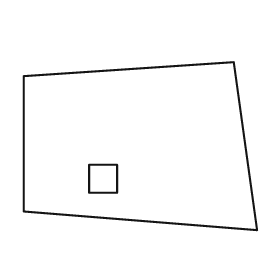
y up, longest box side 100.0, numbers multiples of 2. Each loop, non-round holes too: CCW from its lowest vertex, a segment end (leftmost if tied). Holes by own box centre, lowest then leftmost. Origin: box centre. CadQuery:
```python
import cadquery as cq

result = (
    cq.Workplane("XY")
    .moveTo(50.0, -36.0)
    .lineTo(40.0, 36.0)
    .lineTo(-50.0, 30.0)
    .lineTo(-50.0, -28.0)
    .close()
    .moveTo(-22.0, -20.0)
    .lineTo(-10.0, -20.0)
    .lineTo(-10.0, -8.0)
    .lineTo(-22.0, -8.0)
    .close()
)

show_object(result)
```